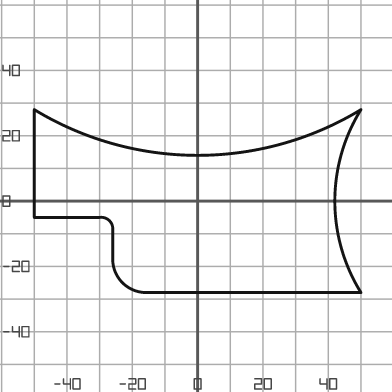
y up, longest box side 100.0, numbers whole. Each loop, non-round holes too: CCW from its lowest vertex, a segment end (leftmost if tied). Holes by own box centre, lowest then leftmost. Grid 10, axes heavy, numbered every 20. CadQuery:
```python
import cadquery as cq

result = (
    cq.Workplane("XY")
    .moveTo(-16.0, -28.0)
    .lineTo(50.0, -28.0)
    .threePointArc((42.0, 0.0), (50.0, 28.0))
    .threePointArc((0.0, 14.0), (-50.0, 28.0))
    .lineTo(-50.0, -5.0)
    .lineTo(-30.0, -5.0)
    .threePointArc((-27.0, -6.0), (-26.0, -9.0))
    .lineTo(-26.0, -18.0)
    .threePointArc((-23.0, -25.0), (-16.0, -28.0))
    .close()
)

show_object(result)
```